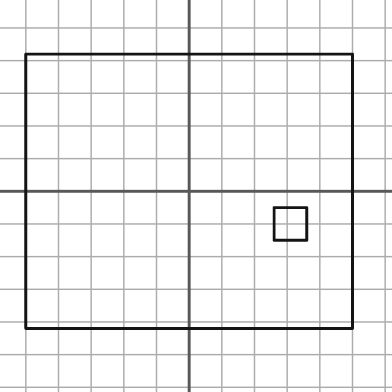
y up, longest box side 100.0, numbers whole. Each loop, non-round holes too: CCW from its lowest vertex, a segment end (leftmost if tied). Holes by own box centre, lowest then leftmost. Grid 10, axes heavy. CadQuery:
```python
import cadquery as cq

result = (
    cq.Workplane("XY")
    .moveTo(-50.0, -42.0)
    .lineTo(50.0, -42.0)
    .lineTo(50.0, 42.0)
    .lineTo(-50.0, 42.0)
    .close()
    .moveTo(26.0, -15.0)
    .lineTo(36.0, -15.0)
    .lineTo(36.0, -5.0)
    .lineTo(26.0, -5.0)
    .close()
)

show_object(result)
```